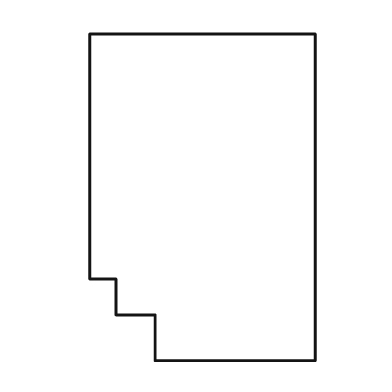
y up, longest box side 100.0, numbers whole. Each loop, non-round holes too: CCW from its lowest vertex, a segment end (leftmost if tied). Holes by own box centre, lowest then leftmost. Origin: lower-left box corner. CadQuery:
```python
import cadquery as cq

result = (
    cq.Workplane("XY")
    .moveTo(20.0, 0.0)
    .lineTo(69.0, 0.0)
    .lineTo(69.0, 100.0)
    .lineTo(0.0, 100.0)
    .lineTo(0.0, 25.0)
    .lineTo(8.0, 25.0)
    .lineTo(8.0, 14.0)
    .lineTo(20.0, 14.0)
    .close()
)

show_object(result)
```